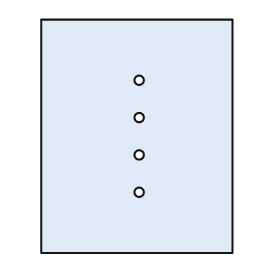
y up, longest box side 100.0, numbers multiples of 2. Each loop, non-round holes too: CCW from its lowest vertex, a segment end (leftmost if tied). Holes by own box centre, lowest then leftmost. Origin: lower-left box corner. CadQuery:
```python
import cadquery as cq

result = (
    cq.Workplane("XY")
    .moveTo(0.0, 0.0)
    .lineTo(82.0, 0.0)
    .lineTo(82.0, 100.0)
    .lineTo(0.0, 100.0)
    .close()
    .moveTo(42.0, 26.0)
    .circle(2.0)
    .moveTo(42.0, 42.0)
    .circle(2.0)
    .moveTo(42.0, 58.0)
    .circle(2.0)
    .moveTo(42.0, 74.0)
    .circle(2.0)
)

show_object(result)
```